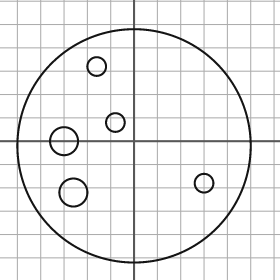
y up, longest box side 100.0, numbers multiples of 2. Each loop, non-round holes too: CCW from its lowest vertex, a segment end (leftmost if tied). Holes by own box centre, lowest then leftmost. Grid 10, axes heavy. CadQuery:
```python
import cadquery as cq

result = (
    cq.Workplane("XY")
    .moveTo(0.0, -2.0)
    .circle(50.0)
    .moveTo(-26.0, -22.0)
    .circle(6.0)
    .moveTo(30.0, -18.0)
    .circle(4.0)
    .moveTo(-30.0, 0.0)
    .circle(6.0)
    .moveTo(-8.0, 8.0)
    .circle(4.0)
    .moveTo(-16.0, 32.0)
    .circle(4.0)
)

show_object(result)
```